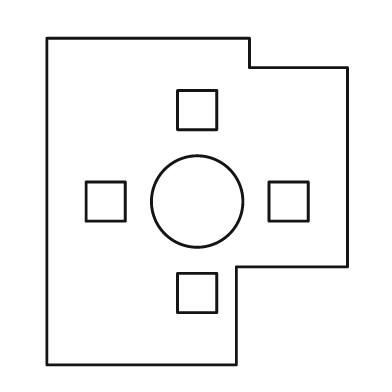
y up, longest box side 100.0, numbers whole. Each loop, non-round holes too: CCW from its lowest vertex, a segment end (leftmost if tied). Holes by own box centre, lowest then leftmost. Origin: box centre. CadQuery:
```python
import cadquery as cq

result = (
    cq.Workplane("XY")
    .moveTo(-46.0, -50.0)
    .lineTo(12.0, -50.0)
    .lineTo(12.0, -20.0)
    .lineTo(46.0, -20.0)
    .lineTo(46.0, 41.0)
    .lineTo(16.0, 41.0)
    .lineTo(16.0, 50.0)
    .lineTo(-46.0, 50.0)
    .close()
    .moveTo(-6.0, -34.0)
    .lineTo(6.0, -34.0)
    .lineTo(6.0, -22.0)
    .lineTo(-6.0, -22.0)
    .close()
    .moveTo(-34.0, -6.0)
    .lineTo(-22.0, -6.0)
    .lineTo(-22.0, 6.0)
    .lineTo(-34.0, 6.0)
    .close()
    .moveTo(0.0, 0.0)
    .circle(14.0)
    .moveTo(22.0, -6.0)
    .lineTo(34.0, -6.0)
    .lineTo(34.0, 6.0)
    .lineTo(22.0, 6.0)
    .close()
    .moveTo(-6.0, 22.0)
    .lineTo(6.0, 22.0)
    .lineTo(6.0, 34.0)
    .lineTo(-6.0, 34.0)
    .close()
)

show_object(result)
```